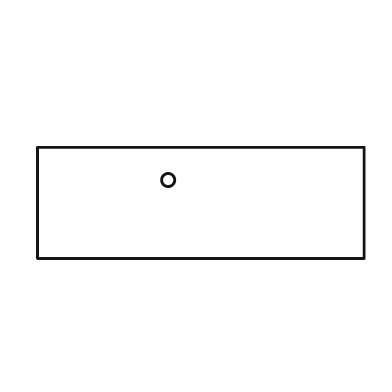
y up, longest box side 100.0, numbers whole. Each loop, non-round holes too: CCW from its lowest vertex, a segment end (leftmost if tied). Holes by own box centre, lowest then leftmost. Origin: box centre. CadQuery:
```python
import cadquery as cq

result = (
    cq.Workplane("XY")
    .moveTo(-50.0, -17.0)
    .lineTo(50.0, -17.0)
    .lineTo(50.0, 17.0)
    .lineTo(-50.0, 17.0)
    .close()
    .moveTo(-10.0, 7.0)
    .circle(2.0)
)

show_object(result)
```